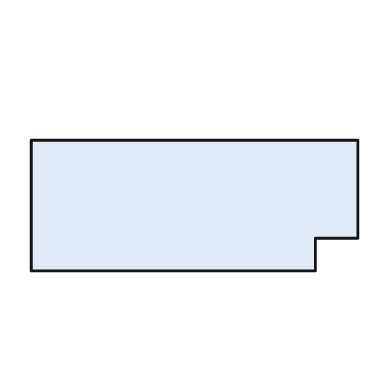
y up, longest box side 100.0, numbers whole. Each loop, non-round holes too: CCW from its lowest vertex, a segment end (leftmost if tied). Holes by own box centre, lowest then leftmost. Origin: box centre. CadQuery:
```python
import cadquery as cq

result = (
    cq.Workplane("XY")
    .moveTo(-50.0, -20.0)
    .lineTo(37.0, -20.0)
    .lineTo(37.0, -10.0)
    .lineTo(50.0, -10.0)
    .lineTo(50.0, 20.0)
    .lineTo(-50.0, 20.0)
    .close()
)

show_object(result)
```